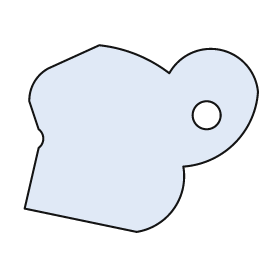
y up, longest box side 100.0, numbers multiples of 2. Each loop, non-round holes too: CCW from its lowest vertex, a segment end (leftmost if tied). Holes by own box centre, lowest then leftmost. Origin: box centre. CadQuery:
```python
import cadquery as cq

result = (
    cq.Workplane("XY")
    .moveTo(-2.0, -40.0)
    .threePointArc((14.0, -30.0), (18.0, -12.0))
    .threePointArc((40.0, -2.0), (50.0, 20.0))
    .threePointArc((34.0, 38.0), (12.0, 28.0))
    .threePointArc((-2.0, 36.0), (-18.0, 40.0))
    .lineTo(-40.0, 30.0)
    .threePointArc((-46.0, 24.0), (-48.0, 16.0))
    .lineTo(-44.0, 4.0)
    .threePointArc((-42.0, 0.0), (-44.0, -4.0))
    .lineTo(-50.0, -30.0)
    .close()
    .moveTo(28.0, 10.0)
    .circle(6.0)
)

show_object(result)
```